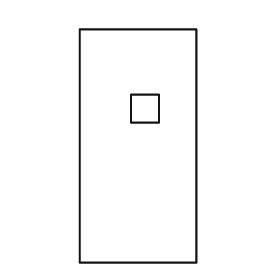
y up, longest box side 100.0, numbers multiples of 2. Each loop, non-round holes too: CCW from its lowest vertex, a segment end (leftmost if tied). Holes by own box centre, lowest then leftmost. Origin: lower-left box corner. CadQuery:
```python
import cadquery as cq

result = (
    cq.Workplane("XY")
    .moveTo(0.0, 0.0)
    .lineTo(50.0, 0.0)
    .lineTo(50.0, 100.0)
    .lineTo(0.0, 100.0)
    .close()
    .moveTo(22.0, 60.0)
    .lineTo(34.0, 60.0)
    .lineTo(34.0, 72.0)
    .lineTo(22.0, 72.0)
    .close()
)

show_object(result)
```